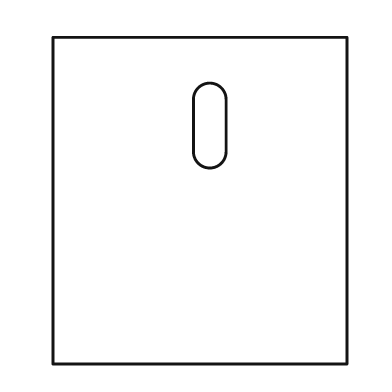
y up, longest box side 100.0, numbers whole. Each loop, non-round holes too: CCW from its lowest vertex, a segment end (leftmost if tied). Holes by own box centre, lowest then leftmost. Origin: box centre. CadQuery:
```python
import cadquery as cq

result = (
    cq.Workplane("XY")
    .moveTo(-45.0, -50.0)
    .lineTo(45.0, -50.0)
    .lineTo(45.0, 50.0)
    .lineTo(-45.0, 50.0)
    .close()
    .moveTo(-2.0, 15.0)
    .threePointArc((3.0, 10.0), (8.0, 15.0))
    .lineTo(8.0, 31.0)
    .threePointArc((3.0, 36.0), (-2.0, 31.0))
    .close()
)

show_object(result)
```